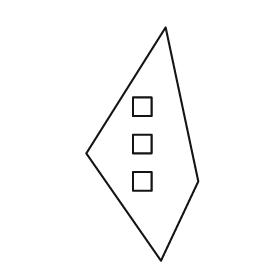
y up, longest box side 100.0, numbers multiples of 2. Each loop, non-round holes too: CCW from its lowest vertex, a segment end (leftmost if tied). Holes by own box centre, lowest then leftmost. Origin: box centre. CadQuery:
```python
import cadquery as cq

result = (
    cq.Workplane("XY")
    .moveTo(8.0, -50.0)
    .lineTo(24.0, -16.0)
    .lineTo(10.0, 50.0)
    .lineTo(-24.0, -4.0)
    .close()
    .moveTo(-4.0, -20.0)
    .lineTo(4.0, -20.0)
    .lineTo(4.0, -12.0)
    .lineTo(-4.0, -12.0)
    .close()
    .moveTo(-4.0, -4.0)
    .lineTo(4.0, -4.0)
    .lineTo(4.0, 4.0)
    .lineTo(-4.0, 4.0)
    .close()
    .moveTo(-4.0, 12.0)
    .lineTo(4.0, 12.0)
    .lineTo(4.0, 20.0)
    .lineTo(-4.0, 20.0)
    .close()
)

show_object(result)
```